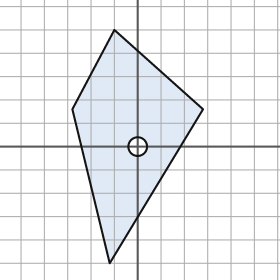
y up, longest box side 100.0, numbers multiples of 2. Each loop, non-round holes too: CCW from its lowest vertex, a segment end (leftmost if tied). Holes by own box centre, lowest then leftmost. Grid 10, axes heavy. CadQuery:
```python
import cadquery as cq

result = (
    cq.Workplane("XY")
    .moveTo(-12.0, -50.0)
    .lineTo(28.0, 16.0)
    .lineTo(-10.0, 50.0)
    .lineTo(-28.0, 16.0)
    .close()
    .moveTo(0.0, 0.0)
    .circle(4.0)
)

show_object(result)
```